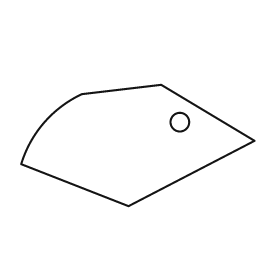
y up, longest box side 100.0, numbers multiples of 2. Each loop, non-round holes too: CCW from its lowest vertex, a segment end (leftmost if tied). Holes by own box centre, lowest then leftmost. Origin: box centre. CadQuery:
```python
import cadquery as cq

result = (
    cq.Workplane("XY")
    .moveTo(-4.0, -26.0)
    .lineTo(50.0, 2.0)
    .lineTo(10.0, 26.0)
    .lineTo(-24.0, 22.0)
    .threePointArc((-40.0, 10.0), (-50.0, -8.0))
    .close()
    .moveTo(18.0, 10.0)
    .circle(4.0)
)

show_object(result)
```